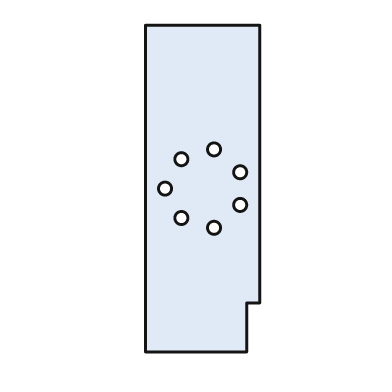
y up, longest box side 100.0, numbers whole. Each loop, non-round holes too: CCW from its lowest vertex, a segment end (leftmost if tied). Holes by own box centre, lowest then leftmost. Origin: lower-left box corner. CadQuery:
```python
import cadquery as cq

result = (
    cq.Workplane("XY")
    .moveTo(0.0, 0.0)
    .lineTo(31.0, 0.0)
    .lineTo(31.0, 15.0)
    .lineTo(35.0, 15.0)
    .lineTo(35.0, 100.0)
    .lineTo(0.0, 100.0)
    .close()
    .moveTo(21.0, 38.0)
    .circle(2.0)
    .moveTo(11.0, 41.0)
    .circle(2.0)
    .moveTo(29.0, 45.0)
    .circle(2.0)
    .moveTo(6.0, 50.0)
    .circle(2.0)
    .moveTo(29.0, 55.0)
    .circle(2.0)
    .moveTo(11.0, 59.0)
    .circle(2.0)
    .moveTo(21.0, 62.0)
    .circle(2.0)
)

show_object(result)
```